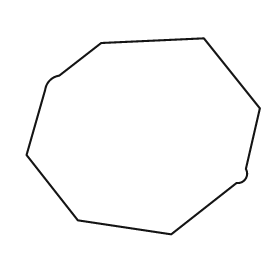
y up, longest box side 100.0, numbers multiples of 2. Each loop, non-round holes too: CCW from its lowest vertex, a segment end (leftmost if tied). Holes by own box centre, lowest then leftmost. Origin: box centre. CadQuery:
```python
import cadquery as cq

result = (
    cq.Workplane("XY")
    .moveTo(12.0, -42.0)
    .lineTo(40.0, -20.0)
    .threePointArc((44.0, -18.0), (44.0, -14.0))
    .lineTo(50.0, 12.0)
    .lineTo(26.0, 42.0)
    .lineTo(-18.0, 40.0)
    .lineTo(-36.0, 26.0)
    .threePointArc((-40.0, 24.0), (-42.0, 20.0))
    .lineTo(-50.0, -8.0)
    .lineTo(-28.0, -36.0)
    .close()
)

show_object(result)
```